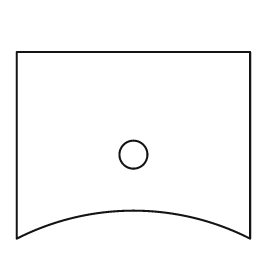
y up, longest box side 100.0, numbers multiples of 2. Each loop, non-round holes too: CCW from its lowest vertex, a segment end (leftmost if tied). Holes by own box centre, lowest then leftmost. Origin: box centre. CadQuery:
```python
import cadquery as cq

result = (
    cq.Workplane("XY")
    .moveTo(-50.0, -40.0)
    .threePointArc((0.0, -28.0), (50.0, -40.0))
    .lineTo(50.0, 40.0)
    .lineTo(-50.0, 40.0)
    .close()
    .moveTo(0.0, -4.0)
    .circle(6.0)
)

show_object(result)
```